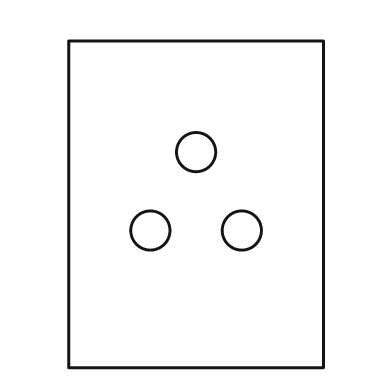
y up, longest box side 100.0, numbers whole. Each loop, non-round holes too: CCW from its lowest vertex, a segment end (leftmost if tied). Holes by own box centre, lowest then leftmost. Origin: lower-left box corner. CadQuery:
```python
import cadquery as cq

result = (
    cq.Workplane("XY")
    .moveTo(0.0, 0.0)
    .lineTo(78.0, 0.0)
    .lineTo(78.0, 100.0)
    .lineTo(0.0, 100.0)
    .close()
    .moveTo(25.0, 42.0)
    .circle(6.0)
    .moveTo(53.0, 42.0)
    .circle(6.0)
    .moveTo(39.0, 66.0)
    .circle(6.0)
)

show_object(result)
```